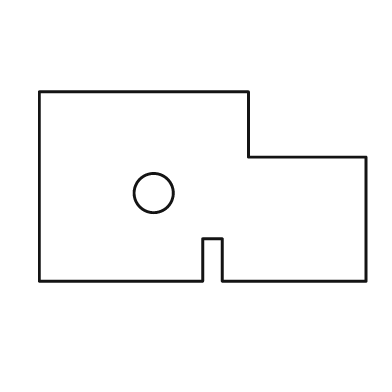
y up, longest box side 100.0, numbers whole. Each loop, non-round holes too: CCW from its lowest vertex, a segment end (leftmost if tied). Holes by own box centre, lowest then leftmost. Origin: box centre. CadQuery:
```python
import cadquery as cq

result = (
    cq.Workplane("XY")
    .moveTo(-50.0, -29.0)
    .lineTo(0.0, -29.0)
    .lineTo(0.0, -16.0)
    .lineTo(6.0, -16.0)
    .lineTo(6.0, -29.0)
    .lineTo(50.0, -29.0)
    .lineTo(50.0, 9.0)
    .lineTo(14.0, 9.0)
    .lineTo(14.0, 29.0)
    .lineTo(-50.0, 29.0)
    .close()
    .moveTo(-15.0, -2.0)
    .circle(6.0)
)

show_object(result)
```